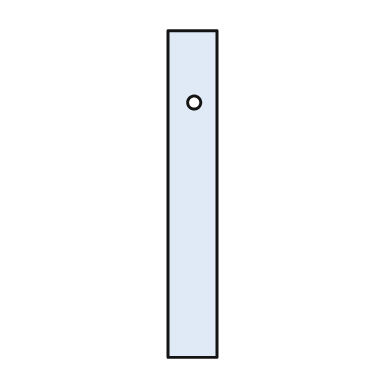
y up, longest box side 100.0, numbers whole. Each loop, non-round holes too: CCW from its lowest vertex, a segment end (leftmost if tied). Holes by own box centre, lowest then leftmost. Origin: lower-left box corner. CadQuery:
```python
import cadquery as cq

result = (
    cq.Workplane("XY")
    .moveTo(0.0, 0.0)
    .lineTo(15.0, 0.0)
    .lineTo(15.0, 100.0)
    .lineTo(0.0, 100.0)
    .close()
    .moveTo(8.0, 78.0)
    .circle(2.0)
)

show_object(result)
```